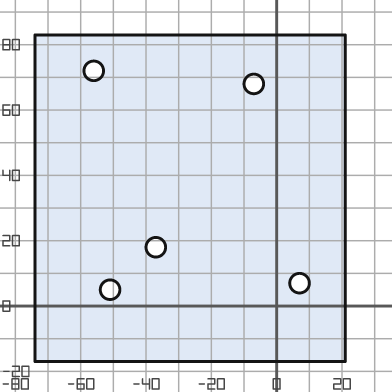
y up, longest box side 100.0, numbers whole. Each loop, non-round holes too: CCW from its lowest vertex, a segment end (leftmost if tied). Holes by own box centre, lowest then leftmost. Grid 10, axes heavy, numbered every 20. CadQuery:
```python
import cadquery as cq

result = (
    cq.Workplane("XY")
    .moveTo(-74.0, -17.0)
    .lineTo(21.0, -17.0)
    .lineTo(21.0, 83.0)
    .lineTo(-74.0, 83.0)
    .close()
    .moveTo(-51.0, 5.0)
    .circle(3.0)
    .moveTo(7.0, 7.0)
    .circle(3.0)
    .moveTo(-37.0, 18.0)
    .circle(3.0)
    .moveTo(-7.0, 68.0)
    .circle(3.0)
    .moveTo(-56.0, 72.0)
    .circle(3.0)
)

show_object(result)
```